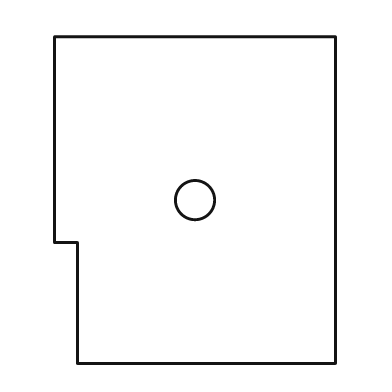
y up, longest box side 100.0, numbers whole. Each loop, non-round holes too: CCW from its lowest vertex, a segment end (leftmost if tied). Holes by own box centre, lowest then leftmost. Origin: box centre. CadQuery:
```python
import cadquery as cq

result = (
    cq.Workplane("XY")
    .moveTo(-36.0, -50.0)
    .lineTo(43.0, -50.0)
    .lineTo(43.0, 50.0)
    .lineTo(-43.0, 50.0)
    .lineTo(-43.0, -13.0)
    .lineTo(-36.0, -13.0)
    .close()
    .moveTo(0.0, 0.0)
    .circle(6.0)
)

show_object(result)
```